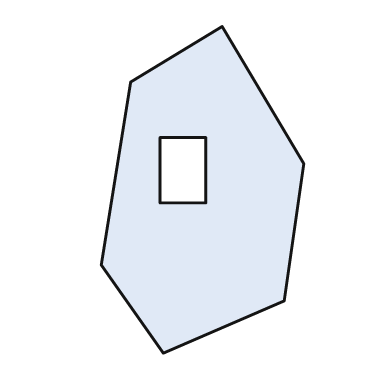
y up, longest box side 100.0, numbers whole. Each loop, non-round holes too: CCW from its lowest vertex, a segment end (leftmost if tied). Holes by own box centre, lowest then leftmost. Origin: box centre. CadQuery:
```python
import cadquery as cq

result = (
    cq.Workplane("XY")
    .moveTo(-12.0, -50.0)
    .lineTo(25.0, -34.0)
    .lineTo(31.0, 8.0)
    .lineTo(6.0, 50.0)
    .lineTo(-22.0, 33.0)
    .lineTo(-31.0, -23.0)
    .close()
    .moveTo(-13.0, -4.0)
    .lineTo(1.0, -4.0)
    .lineTo(1.0, 16.0)
    .lineTo(-13.0, 16.0)
    .close()
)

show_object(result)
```